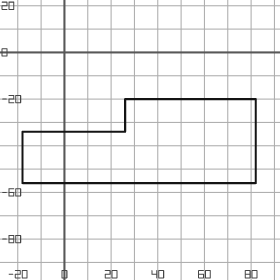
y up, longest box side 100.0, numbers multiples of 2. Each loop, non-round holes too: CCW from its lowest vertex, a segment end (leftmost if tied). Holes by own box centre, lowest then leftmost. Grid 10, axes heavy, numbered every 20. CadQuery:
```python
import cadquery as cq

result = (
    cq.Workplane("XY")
    .moveTo(-18.0, -56.0)
    .lineTo(82.0, -56.0)
    .lineTo(82.0, -20.0)
    .lineTo(26.0, -20.0)
    .lineTo(26.0, -34.0)
    .lineTo(-18.0, -34.0)
    .close()
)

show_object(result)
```